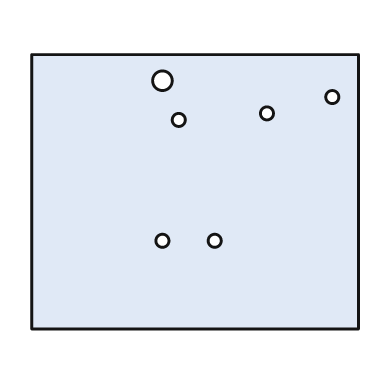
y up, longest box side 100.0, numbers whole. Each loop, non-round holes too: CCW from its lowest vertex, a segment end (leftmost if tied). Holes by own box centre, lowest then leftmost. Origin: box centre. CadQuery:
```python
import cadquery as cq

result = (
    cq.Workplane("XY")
    .moveTo(-50.0, -42.0)
    .lineTo(50.0, -42.0)
    .lineTo(50.0, 42.0)
    .lineTo(-50.0, 42.0)
    .close()
    .moveTo(-10.0, -15.0)
    .circle(2.0)
    .moveTo(6.0, -15.0)
    .circle(2.0)
    .moveTo(-5.0, 22.0)
    .circle(2.0)
    .moveTo(22.0, 24.0)
    .circle(2.0)
    .moveTo(42.0, 29.0)
    .circle(2.0)
    .moveTo(-10.0, 34.0)
    .circle(3.0)
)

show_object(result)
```